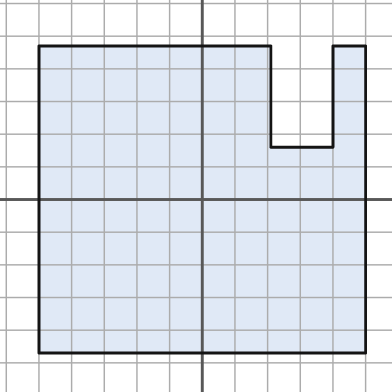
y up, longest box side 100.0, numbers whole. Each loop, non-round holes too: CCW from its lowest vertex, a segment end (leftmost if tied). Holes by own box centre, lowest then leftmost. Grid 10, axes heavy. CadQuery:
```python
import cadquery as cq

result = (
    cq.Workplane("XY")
    .moveTo(-50.0, -47.0)
    .lineTo(50.0, -47.0)
    .lineTo(50.0, 47.0)
    .lineTo(40.0, 47.0)
    .lineTo(40.0, 16.0)
    .lineTo(21.0, 16.0)
    .lineTo(21.0, 47.0)
    .lineTo(-50.0, 47.0)
    .close()
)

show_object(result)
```